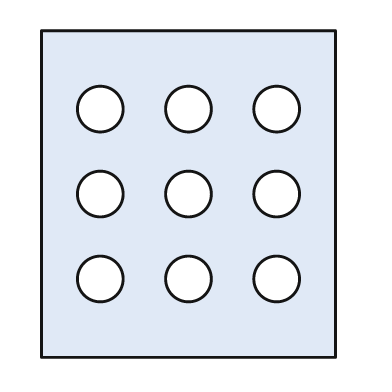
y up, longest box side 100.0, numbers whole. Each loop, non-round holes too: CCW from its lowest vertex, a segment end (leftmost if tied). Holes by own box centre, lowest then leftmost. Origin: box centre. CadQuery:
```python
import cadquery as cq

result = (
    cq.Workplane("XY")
    .moveTo(-45.0, -50.0)
    .lineTo(45.0, -50.0)
    .lineTo(45.0, 50.0)
    .lineTo(-45.0, 50.0)
    .close()
    .moveTo(-27.0, -26.0)
    .circle(7.0)
    .moveTo(0.0, -26.0)
    .circle(7.0)
    .moveTo(27.0, -26.0)
    .circle(7.0)
    .moveTo(-27.0, 0.0)
    .circle(7.0)
    .moveTo(0.0, 0.0)
    .circle(7.0)
    .moveTo(27.0, 0.0)
    .circle(7.0)
    .moveTo(-27.0, 26.0)
    .circle(7.0)
    .moveTo(0.0, 26.0)
    .circle(7.0)
    .moveTo(27.0, 26.0)
    .circle(7.0)
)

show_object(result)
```